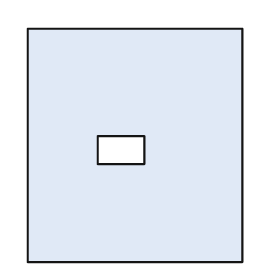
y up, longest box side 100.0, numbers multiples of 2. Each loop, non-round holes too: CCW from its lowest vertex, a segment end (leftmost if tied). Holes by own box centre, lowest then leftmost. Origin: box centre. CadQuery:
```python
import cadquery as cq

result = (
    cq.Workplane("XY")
    .moveTo(-46.0, -50.0)
    .lineTo(46.0, -50.0)
    .lineTo(46.0, 50.0)
    .lineTo(-46.0, 50.0)
    .close()
    .moveTo(-16.0, -8.0)
    .lineTo(4.0, -8.0)
    .lineTo(4.0, 4.0)
    .lineTo(-16.0, 4.0)
    .close()
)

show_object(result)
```